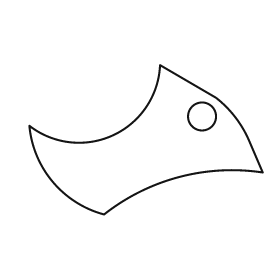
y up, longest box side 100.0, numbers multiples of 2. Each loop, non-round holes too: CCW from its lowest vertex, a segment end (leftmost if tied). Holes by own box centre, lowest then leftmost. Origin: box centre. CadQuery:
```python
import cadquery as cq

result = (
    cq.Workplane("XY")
    .moveTo(-18.0, -32.0)
    .threePointArc((14.0, -16.0), (50.0, -14.0))
    .lineTo(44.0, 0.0)
    .threePointArc((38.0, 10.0), (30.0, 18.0))
    .lineTo(6.0, 32.0)
    .threePointArc((-14.0, 2.0), (-50.0, 6.0))
    .threePointArc((-40.0, -18.0), (-18.0, -32.0))
    .close()
    .moveTo(24.0, 10.0)
    .circle(6.0)
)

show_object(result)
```